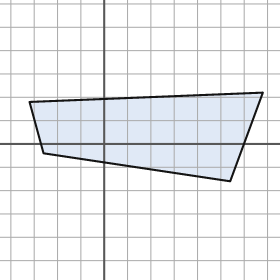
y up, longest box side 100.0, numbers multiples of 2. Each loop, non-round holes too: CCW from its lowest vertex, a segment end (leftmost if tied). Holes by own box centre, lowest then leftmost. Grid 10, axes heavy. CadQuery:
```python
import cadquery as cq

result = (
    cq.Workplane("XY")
    .moveTo(54.0, -16.0)
    .lineTo(68.0, 22.0)
    .lineTo(-32.0, 18.0)
    .lineTo(-26.0, -4.0)
    .close()
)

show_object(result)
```